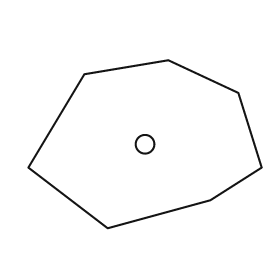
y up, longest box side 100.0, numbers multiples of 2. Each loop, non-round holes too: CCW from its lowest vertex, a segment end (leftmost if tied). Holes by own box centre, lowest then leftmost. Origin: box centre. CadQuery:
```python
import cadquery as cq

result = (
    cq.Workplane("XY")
    .moveTo(-16.0, -36.0)
    .lineTo(28.0, -24.0)
    .lineTo(50.0, -10.0)
    .lineTo(40.0, 22.0)
    .lineTo(10.0, 36.0)
    .lineTo(-26.0, 30.0)
    .lineTo(-50.0, -10.0)
    .close()
    .moveTo(0.0, 0.0)
    .circle(4.0)
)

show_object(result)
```